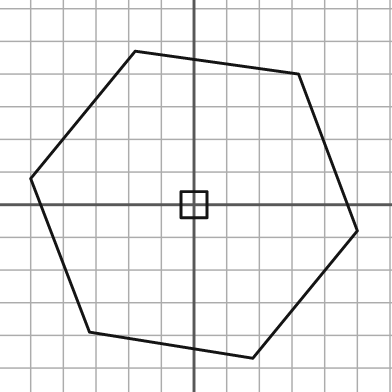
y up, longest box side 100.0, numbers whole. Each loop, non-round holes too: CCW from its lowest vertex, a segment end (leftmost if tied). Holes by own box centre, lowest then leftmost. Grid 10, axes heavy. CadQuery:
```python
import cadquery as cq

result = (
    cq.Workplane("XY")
    .moveTo(18.0, -47.0)
    .lineTo(50.0, -8.0)
    .lineTo(32.0, 40.0)
    .lineTo(-18.0, 47.0)
    .lineTo(-50.0, 8.0)
    .lineTo(-32.0, -39.0)
    .close()
    .moveTo(-4.0, -4.0)
    .lineTo(4.0, -4.0)
    .lineTo(4.0, 4.0)
    .lineTo(-4.0, 4.0)
    .close()
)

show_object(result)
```